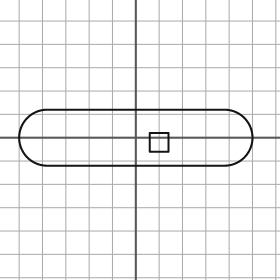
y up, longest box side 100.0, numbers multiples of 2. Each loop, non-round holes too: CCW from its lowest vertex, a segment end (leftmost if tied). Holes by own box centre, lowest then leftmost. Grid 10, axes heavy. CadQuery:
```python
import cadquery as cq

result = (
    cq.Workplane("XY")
    .moveTo(-38.0, -12.0)
    .lineTo(38.0, -12.0)
    .threePointArc((50.0, 0.0), (38.0, 12.0))
    .lineTo(-38.0, 12.0)
    .threePointArc((-50.0, 0.0), (-38.0, -12.0))
    .close()
    .moveTo(6.0, -6.0)
    .lineTo(14.0, -6.0)
    .lineTo(14.0, 2.0)
    .lineTo(6.0, 2.0)
    .close()
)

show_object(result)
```